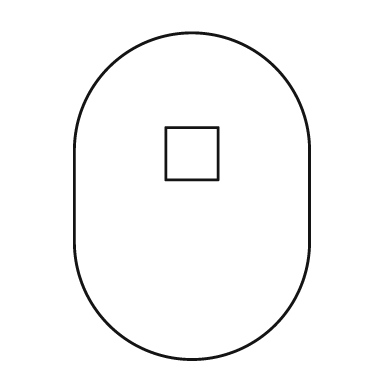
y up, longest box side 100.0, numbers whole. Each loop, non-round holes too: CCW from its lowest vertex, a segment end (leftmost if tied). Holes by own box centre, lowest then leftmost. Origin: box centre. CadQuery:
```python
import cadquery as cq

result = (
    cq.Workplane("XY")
    .moveTo(-36.0, -14.0)
    .threePointArc((0.0, -50.0), (36.0, -14.0))
    .lineTo(36.0, 14.0)
    .threePointArc((0.0, 50.0), (-36.0, 14.0))
    .close()
    .moveTo(-8.0, 5.0)
    .lineTo(8.0, 5.0)
    .lineTo(8.0, 21.0)
    .lineTo(-8.0, 21.0)
    .close()
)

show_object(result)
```